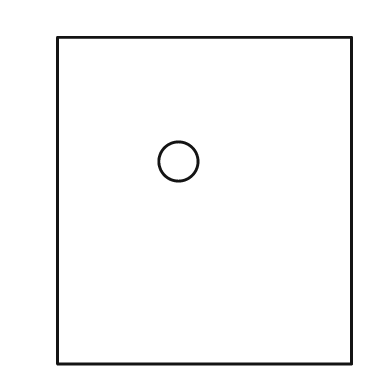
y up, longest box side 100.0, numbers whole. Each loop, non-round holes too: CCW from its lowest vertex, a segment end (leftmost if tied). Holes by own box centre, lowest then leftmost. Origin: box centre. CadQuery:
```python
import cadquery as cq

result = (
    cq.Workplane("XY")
    .moveTo(-45.0, -50.0)
    .lineTo(45.0, -50.0)
    .lineTo(45.0, 50.0)
    .lineTo(-45.0, 50.0)
    .close()
    .moveTo(-8.0, 12.0)
    .circle(6.0)
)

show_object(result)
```